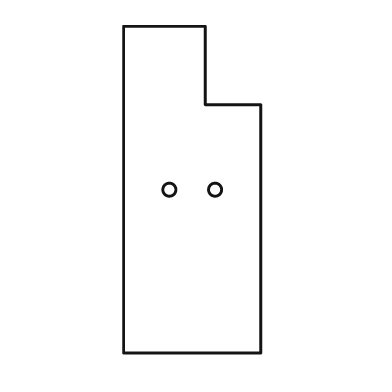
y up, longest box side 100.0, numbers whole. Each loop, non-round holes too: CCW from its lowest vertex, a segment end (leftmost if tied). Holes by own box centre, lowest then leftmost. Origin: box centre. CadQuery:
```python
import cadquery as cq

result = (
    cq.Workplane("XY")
    .moveTo(-21.0, -50.0)
    .lineTo(21.0, -50.0)
    .lineTo(21.0, 26.0)
    .lineTo(4.0, 26.0)
    .lineTo(4.0, 50.0)
    .lineTo(-21.0, 50.0)
    .close()
    .moveTo(-7.0, 0.0)
    .circle(2.0)
    .moveTo(7.0, 0.0)
    .circle(2.0)
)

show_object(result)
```